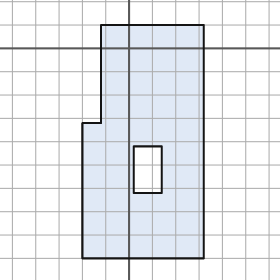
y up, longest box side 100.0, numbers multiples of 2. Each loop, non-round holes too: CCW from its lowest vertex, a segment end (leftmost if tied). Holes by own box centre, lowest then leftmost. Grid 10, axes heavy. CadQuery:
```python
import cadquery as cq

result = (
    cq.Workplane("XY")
    .moveTo(-20.0, -90.0)
    .lineTo(32.0, -90.0)
    .lineTo(32.0, 10.0)
    .lineTo(-12.0, 10.0)
    .lineTo(-12.0, -32.0)
    .lineTo(-20.0, -32.0)
    .close()
    .moveTo(2.0, -62.0)
    .lineTo(14.0, -62.0)
    .lineTo(14.0, -42.0)
    .lineTo(2.0, -42.0)
    .close()
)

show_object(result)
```